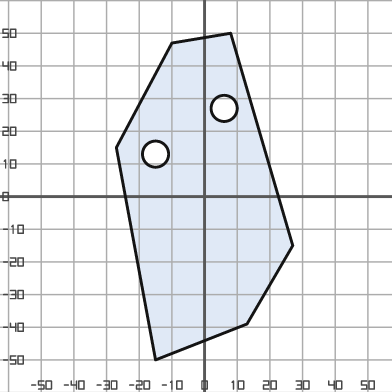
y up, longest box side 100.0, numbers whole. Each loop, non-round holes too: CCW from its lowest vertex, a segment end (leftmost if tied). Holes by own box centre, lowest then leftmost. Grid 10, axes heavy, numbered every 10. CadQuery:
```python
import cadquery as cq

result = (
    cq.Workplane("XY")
    .moveTo(-15.0, -50.0)
    .lineTo(13.0, -39.0)
    .lineTo(27.0, -15.0)
    .lineTo(8.0, 50.0)
    .lineTo(-10.0, 47.0)
    .lineTo(-27.0, 15.0)
    .close()
    .moveTo(-15.0, 13.0)
    .circle(4.0)
    .moveTo(6.0, 27.0)
    .circle(4.0)
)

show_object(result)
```